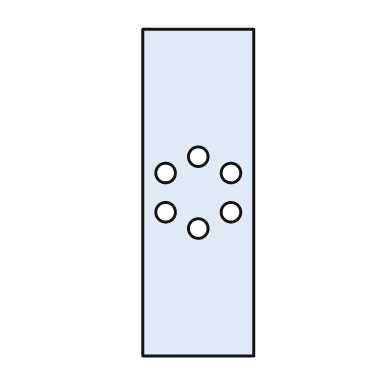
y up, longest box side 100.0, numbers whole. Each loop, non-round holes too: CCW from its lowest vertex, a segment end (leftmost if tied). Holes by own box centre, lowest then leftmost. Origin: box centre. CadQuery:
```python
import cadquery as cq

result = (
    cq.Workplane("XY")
    .moveTo(-17.0, -50.0)
    .lineTo(17.0, -50.0)
    .lineTo(17.0, 50.0)
    .lineTo(-17.0, 50.0)
    .close()
    .moveTo(0.0, -11.0)
    .circle(3.0)
    .moveTo(-10.0, -6.0)
    .circle(3.0)
    .moveTo(10.0, -6.0)
    .circle(3.0)
    .moveTo(-10.0, 6.0)
    .circle(3.0)
    .moveTo(10.0, 6.0)
    .circle(3.0)
    .moveTo(0.0, 11.0)
    .circle(3.0)
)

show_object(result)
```